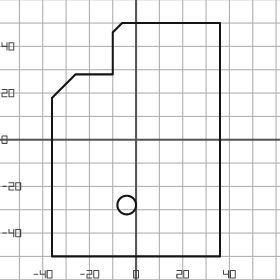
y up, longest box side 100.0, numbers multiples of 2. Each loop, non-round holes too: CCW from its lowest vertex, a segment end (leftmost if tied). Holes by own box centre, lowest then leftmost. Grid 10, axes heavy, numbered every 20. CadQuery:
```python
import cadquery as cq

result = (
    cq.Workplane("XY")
    .moveTo(-36.0, -50.0)
    .lineTo(36.0, -50.0)
    .lineTo(36.0, 50.0)
    .lineTo(-6.0, 50.0)
    .lineTo(-10.0, 46.0)
    .lineTo(-10.0, 28.0)
    .lineTo(-26.0, 28.0)
    .lineTo(-36.0, 18.0)
    .close()
    .moveTo(-4.0, -28.0)
    .circle(4.0)
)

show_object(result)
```